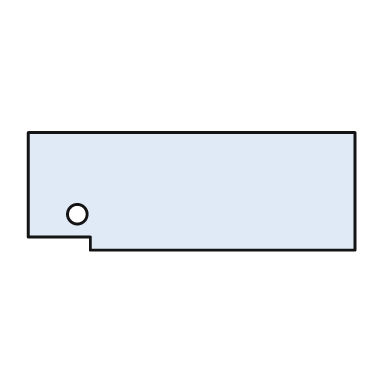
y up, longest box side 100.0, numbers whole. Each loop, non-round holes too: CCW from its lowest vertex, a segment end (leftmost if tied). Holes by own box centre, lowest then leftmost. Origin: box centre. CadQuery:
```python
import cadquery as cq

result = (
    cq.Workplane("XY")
    .moveTo(-31.0, -18.0)
    .lineTo(50.0, -18.0)
    .lineTo(50.0, 18.0)
    .lineTo(-50.0, 18.0)
    .lineTo(-50.0, -14.0)
    .lineTo(-31.0, -14.0)
    .close()
    .moveTo(-35.0, -7.0)
    .circle(3.0)
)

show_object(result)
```